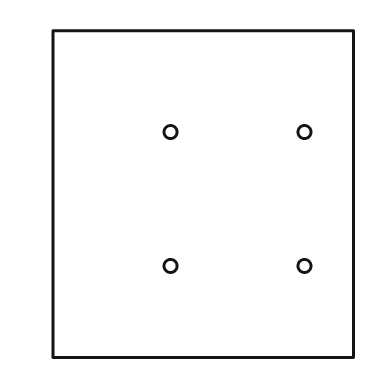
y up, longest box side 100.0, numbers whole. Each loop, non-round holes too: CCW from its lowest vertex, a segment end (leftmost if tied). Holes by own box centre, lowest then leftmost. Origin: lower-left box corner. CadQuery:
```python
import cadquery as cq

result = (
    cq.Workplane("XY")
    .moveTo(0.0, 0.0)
    .lineTo(92.0, 0.0)
    .lineTo(92.0, 100.0)
    .lineTo(0.0, 100.0)
    .close()
    .moveTo(36.0, 28.0)
    .circle(2.0)
    .moveTo(77.0, 28.0)
    .circle(2.0)
    .moveTo(36.0, 69.0)
    .circle(2.0)
    .moveTo(77.0, 69.0)
    .circle(2.0)
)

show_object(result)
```